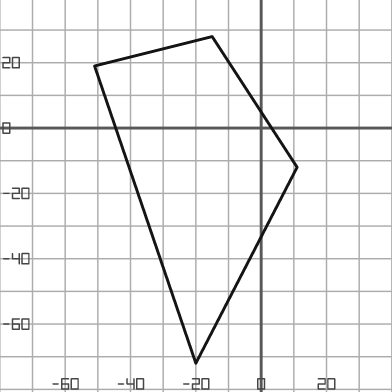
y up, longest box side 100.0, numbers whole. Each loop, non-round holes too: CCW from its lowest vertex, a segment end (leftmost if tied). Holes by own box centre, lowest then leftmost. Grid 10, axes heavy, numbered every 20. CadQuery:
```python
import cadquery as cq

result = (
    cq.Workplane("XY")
    .moveTo(-20.0, -72.0)
    .lineTo(11.0, -12.0)
    .lineTo(-15.0, 28.0)
    .lineTo(-51.0, 19.0)
    .close()
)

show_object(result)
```